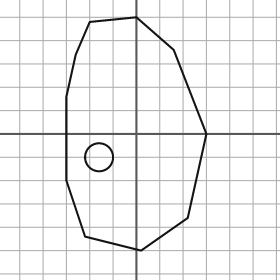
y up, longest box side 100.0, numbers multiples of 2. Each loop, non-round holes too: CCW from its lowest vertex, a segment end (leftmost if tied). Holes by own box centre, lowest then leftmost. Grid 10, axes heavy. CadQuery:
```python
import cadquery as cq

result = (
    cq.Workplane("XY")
    .moveTo(2.0, -50.0)
    .lineTo(22.0, -36.0)
    .lineTo(30.0, 0.0)
    .lineTo(16.0, 36.0)
    .lineTo(0.0, 50.0)
    .lineTo(-20.0, 48.0)
    .lineTo(-26.0, 34.0)
    .lineTo(-30.0, 16.0)
    .lineTo(-30.0, -20.0)
    .lineTo(-22.0, -44.0)
    .close()
    .moveTo(-16.0, -10.0)
    .circle(6.0)
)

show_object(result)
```